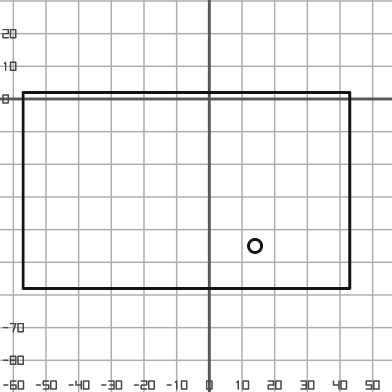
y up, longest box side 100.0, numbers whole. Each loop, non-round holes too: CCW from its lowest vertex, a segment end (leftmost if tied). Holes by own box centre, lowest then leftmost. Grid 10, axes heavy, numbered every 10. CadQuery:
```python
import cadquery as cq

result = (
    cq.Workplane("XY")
    .moveTo(-57.0, -58.0)
    .lineTo(43.0, -58.0)
    .lineTo(43.0, 2.0)
    .lineTo(-57.0, 2.0)
    .close()
    .moveTo(14.0, -45.0)
    .circle(2.0)
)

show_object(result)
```